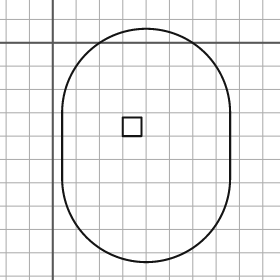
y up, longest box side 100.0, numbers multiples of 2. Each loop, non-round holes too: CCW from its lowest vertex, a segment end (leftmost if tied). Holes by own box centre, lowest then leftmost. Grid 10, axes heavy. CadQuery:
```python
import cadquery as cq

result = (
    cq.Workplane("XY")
    .moveTo(4.0, -58.0)
    .threePointArc((40.0, -94.0), (76.0, -58.0))
    .lineTo(76.0, -30.0)
    .threePointArc((40.0, 6.0), (4.0, -30.0))
    .close()
    .moveTo(30.0, -40.0)
    .lineTo(38.0, -40.0)
    .lineTo(38.0, -32.0)
    .lineTo(30.0, -32.0)
    .close()
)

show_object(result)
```